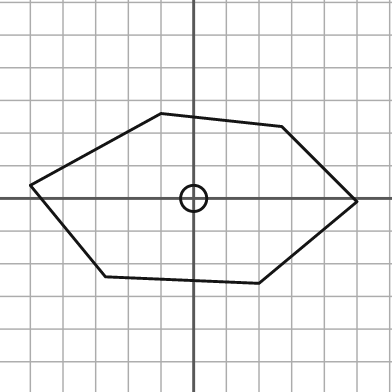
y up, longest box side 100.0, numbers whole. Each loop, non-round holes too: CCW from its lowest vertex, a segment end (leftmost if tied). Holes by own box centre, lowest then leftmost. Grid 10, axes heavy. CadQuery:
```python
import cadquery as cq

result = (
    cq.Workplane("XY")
    .moveTo(20.0, -26.0)
    .lineTo(50.0, -1.0)
    .lineTo(27.0, 22.0)
    .lineTo(-10.0, 26.0)
    .lineTo(-50.0, 4.0)
    .lineTo(-27.0, -24.0)
    .close()
    .moveTo(0.0, 0.0)
    .circle(4.0)
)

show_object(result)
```